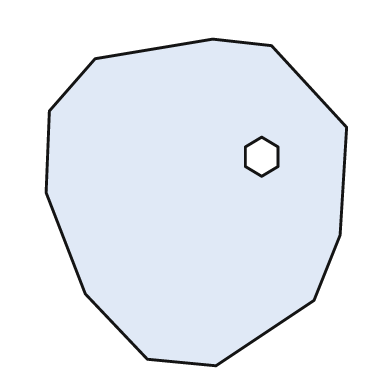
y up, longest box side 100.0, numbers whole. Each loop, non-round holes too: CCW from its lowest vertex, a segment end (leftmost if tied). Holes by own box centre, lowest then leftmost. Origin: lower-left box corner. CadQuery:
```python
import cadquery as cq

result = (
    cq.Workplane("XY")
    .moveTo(52.0, 0.0)
    .lineTo(82.0, 20.0)
    .lineTo(90.0, 40.0)
    .lineTo(92.0, 73.0)
    .lineTo(69.0, 98.0)
    .lineTo(51.0, 100.0)
    .lineTo(15.0, 94.0)
    .lineTo(1.0, 78.0)
    .lineTo(0.0, 53.0)
    .lineTo(12.0, 22.0)
    .lineTo(31.0, 2.0)
    .close()
    .moveTo(66.0, 58.0)
    .lineTo(71.0, 61.0)
    .lineTo(71.0, 67.0)
    .lineTo(66.0, 70.0)
    .lineTo(61.0, 67.0)
    .lineTo(61.0, 61.0)
    .close()
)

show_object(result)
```